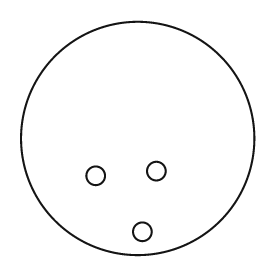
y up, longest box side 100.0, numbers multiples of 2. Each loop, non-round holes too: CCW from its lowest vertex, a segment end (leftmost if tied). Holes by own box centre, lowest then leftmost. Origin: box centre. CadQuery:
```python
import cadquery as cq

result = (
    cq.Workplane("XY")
    .moveTo(0.0, 0.0)
    .circle(50.0)
    .moveTo(2.0, -40.0)
    .circle(4.0)
    .moveTo(-18.0, -16.0)
    .circle(4.0)
    .moveTo(8.0, -14.0)
    .circle(4.0)
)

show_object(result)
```